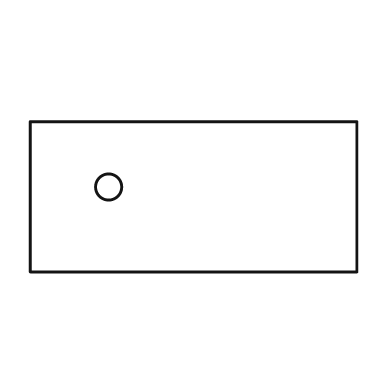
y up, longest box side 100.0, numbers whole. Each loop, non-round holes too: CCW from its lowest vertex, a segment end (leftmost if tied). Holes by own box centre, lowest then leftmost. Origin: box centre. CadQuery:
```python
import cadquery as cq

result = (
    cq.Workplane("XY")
    .moveTo(-50.0, -23.0)
    .lineTo(50.0, -23.0)
    .lineTo(50.0, 23.0)
    .lineTo(-50.0, 23.0)
    .close()
    .moveTo(-26.0, 3.0)
    .circle(4.0)
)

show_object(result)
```